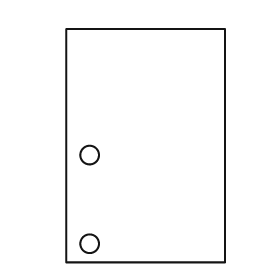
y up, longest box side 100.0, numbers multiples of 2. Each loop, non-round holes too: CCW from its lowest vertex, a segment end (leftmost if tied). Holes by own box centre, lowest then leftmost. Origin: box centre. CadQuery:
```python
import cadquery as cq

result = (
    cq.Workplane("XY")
    .moveTo(-34.0, -50.0)
    .lineTo(34.0, -50.0)
    .lineTo(34.0, 50.0)
    .lineTo(-34.0, 50.0)
    .close()
    .moveTo(-24.0, -42.0)
    .circle(4.0)
    .moveTo(-24.0, -4.0)
    .circle(4.0)
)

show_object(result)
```